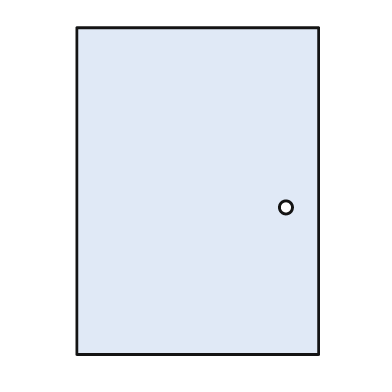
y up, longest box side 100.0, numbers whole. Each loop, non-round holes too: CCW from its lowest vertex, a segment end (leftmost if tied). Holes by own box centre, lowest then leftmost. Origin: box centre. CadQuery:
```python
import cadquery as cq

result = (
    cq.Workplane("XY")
    .moveTo(-37.0, -50.0)
    .lineTo(37.0, -50.0)
    .lineTo(37.0, 50.0)
    .lineTo(-37.0, 50.0)
    .close()
    .moveTo(27.0, -5.0)
    .circle(2.0)
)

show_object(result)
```